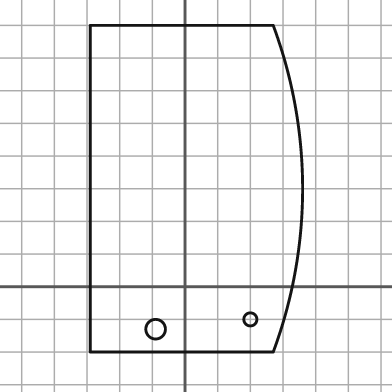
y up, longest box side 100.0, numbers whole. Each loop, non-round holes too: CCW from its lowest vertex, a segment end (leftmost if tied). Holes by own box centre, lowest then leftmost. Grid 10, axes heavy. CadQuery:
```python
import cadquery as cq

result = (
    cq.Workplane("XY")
    .moveTo(-29.0, -20.0)
    .lineTo(27.0, -20.0)
    .threePointArc((36.0, 30.0), (27.0, 80.0))
    .lineTo(-29.0, 80.0)
    .close()
    .moveTo(-9.0, -13.0)
    .circle(3.0)
    .moveTo(20.0, -10.0)
    .circle(2.0)
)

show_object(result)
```